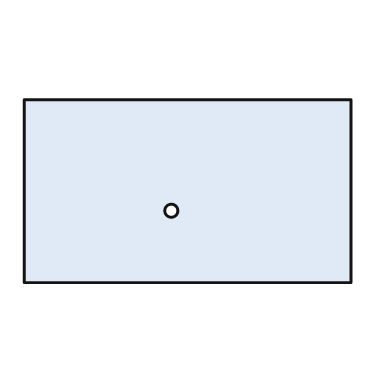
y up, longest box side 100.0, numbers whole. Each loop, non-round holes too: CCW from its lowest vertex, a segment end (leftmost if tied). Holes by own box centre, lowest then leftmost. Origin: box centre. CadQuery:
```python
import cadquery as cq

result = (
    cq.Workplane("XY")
    .moveTo(-50.0, -28.0)
    .lineTo(50.0, -28.0)
    .lineTo(50.0, 28.0)
    .lineTo(-50.0, 28.0)
    .close()
    .moveTo(-5.0, -6.0)
    .circle(2.0)
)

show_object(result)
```